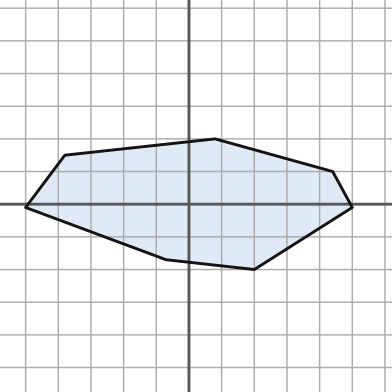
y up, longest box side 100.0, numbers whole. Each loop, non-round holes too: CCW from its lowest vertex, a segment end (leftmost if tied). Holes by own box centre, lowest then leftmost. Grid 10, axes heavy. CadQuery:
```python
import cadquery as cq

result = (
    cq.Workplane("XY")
    .moveTo(20.0, -20.0)
    .lineTo(50.0, -1.0)
    .lineTo(44.0, 10.0)
    .lineTo(8.0, 20.0)
    .lineTo(-38.0, 15.0)
    .lineTo(-50.0, -1.0)
    .lineTo(-7.0, -17.0)
    .close()
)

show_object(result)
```